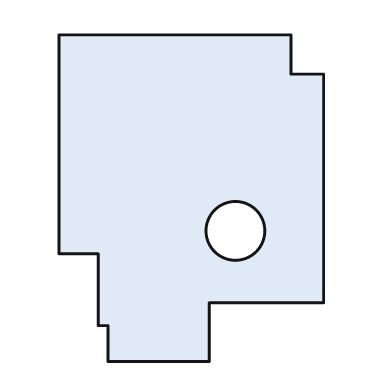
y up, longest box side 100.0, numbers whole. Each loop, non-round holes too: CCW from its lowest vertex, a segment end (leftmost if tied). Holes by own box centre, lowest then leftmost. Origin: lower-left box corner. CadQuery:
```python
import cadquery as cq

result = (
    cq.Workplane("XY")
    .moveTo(15.0, 0.0)
    .lineTo(46.0, 0.0)
    .lineTo(46.0, 18.0)
    .lineTo(81.0, 18.0)
    .lineTo(81.0, 88.0)
    .lineTo(71.0, 88.0)
    .lineTo(71.0, 100.0)
    .lineTo(0.0, 100.0)
    .lineTo(0.0, 33.0)
    .lineTo(12.0, 33.0)
    .lineTo(12.0, 11.0)
    .lineTo(15.0, 11.0)
    .close()
    .moveTo(54.0, 40.0)
    .circle(9.0)
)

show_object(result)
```